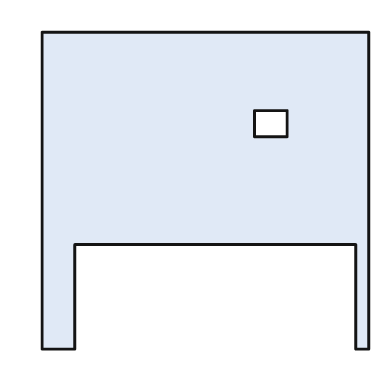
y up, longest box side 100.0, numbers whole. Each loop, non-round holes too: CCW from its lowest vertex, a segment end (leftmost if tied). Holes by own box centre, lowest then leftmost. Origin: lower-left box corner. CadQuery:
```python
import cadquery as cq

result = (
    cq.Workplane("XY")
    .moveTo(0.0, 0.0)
    .lineTo(10.0, 0.0)
    .lineTo(10.0, 32.0)
    .lineTo(96.0, 32.0)
    .lineTo(96.0, 0.0)
    .lineTo(100.0, 0.0)
    .lineTo(100.0, 97.0)
    .lineTo(0.0, 97.0)
    .close()
    .moveTo(65.0, 65.0)
    .lineTo(75.0, 65.0)
    .lineTo(75.0, 73.0)
    .lineTo(65.0, 73.0)
    .close()
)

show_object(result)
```